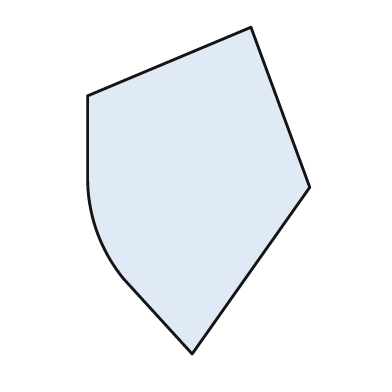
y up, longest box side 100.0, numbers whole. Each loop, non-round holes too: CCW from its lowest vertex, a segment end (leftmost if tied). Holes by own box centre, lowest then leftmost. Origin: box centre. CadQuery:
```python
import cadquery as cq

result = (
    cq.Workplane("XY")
    .moveTo(-2.0, -50.0)
    .lineTo(34.0, 1.0)
    .lineTo(16.0, 50.0)
    .lineTo(-34.0, 29.0)
    .lineTo(-34.0, 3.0)
    .threePointArc((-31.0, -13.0), (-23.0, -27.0))
    .close()
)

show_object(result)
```